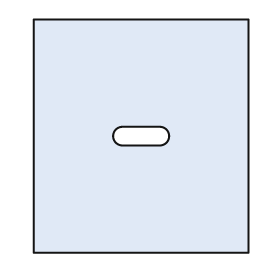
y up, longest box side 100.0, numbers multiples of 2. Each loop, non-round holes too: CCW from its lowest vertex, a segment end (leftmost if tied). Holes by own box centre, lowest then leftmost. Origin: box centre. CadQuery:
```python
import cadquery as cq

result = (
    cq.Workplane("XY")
    .moveTo(-46.0, -50.0)
    .lineTo(46.0, -50.0)
    .lineTo(46.0, 50.0)
    .lineTo(-46.0, 50.0)
    .close()
    .moveTo(-8.0, -4.0)
    .lineTo(8.0, -4.0)
    .threePointArc((12.0, 0.0), (8.0, 4.0))
    .lineTo(-8.0, 4.0)
    .threePointArc((-12.0, 0.0), (-8.0, -4.0))
    .close()
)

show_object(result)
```